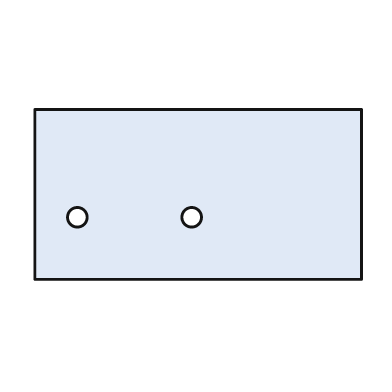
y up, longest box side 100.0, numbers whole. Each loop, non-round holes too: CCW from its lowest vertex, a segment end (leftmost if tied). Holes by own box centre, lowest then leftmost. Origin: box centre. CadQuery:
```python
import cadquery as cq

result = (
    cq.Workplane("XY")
    .moveTo(-50.0, -26.0)
    .lineTo(50.0, -26.0)
    .lineTo(50.0, 26.0)
    .lineTo(-50.0, 26.0)
    .close()
    .moveTo(-37.0, -7.0)
    .circle(3.0)
    .moveTo(-2.0, -7.0)
    .circle(3.0)
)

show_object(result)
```